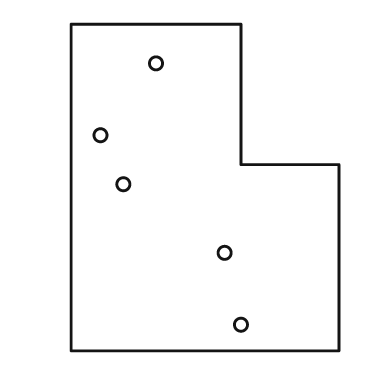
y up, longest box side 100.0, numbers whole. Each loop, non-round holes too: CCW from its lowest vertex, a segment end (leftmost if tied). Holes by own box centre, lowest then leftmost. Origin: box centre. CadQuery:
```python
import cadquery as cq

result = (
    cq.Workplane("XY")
    .moveTo(-41.0, -50.0)
    .lineTo(41.0, -50.0)
    .lineTo(41.0, 7.0)
    .lineTo(11.0, 7.0)
    .lineTo(11.0, 50.0)
    .lineTo(-41.0, 50.0)
    .close()
    .moveTo(11.0, -42.0)
    .circle(2.0)
    .moveTo(6.0, -20.0)
    .circle(2.0)
    .moveTo(-25.0, 1.0)
    .circle(2.0)
    .moveTo(-32.0, 16.0)
    .circle(2.0)
    .moveTo(-15.0, 38.0)
    .circle(2.0)
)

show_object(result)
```